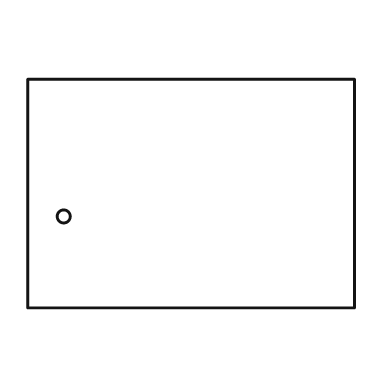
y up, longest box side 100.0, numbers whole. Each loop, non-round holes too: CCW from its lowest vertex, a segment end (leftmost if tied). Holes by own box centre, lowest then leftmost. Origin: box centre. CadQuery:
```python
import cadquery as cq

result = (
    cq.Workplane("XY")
    .moveTo(-50.0, -35.0)
    .lineTo(50.0, -35.0)
    .lineTo(50.0, 35.0)
    .lineTo(-50.0, 35.0)
    .close()
    .moveTo(-39.0, -7.0)
    .circle(2.0)
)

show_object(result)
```